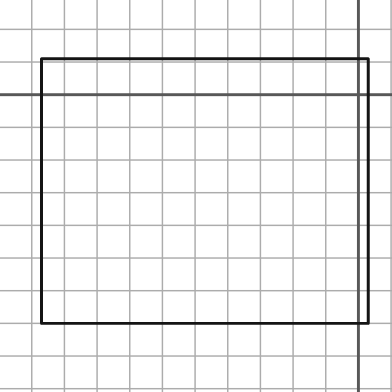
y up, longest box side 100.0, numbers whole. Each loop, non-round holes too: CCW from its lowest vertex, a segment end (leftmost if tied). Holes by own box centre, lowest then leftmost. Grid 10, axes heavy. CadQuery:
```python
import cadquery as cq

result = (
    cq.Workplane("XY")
    .moveTo(-97.0, -70.0)
    .lineTo(3.0, -70.0)
    .lineTo(3.0, 11.0)
    .lineTo(-97.0, 11.0)
    .close()
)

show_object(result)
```